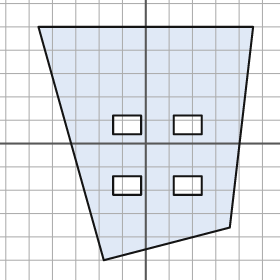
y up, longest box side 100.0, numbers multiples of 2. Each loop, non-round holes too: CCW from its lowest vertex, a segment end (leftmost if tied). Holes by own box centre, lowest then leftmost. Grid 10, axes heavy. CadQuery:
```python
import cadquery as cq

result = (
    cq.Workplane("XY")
    .moveTo(-18.0, -50.0)
    .lineTo(36.0, -36.0)
    .lineTo(46.0, 50.0)
    .lineTo(-46.0, 50.0)
    .close()
    .moveTo(-14.0, -22.0)
    .lineTo(-2.0, -22.0)
    .lineTo(-2.0, -14.0)
    .lineTo(-14.0, -14.0)
    .close()
    .moveTo(12.0, -22.0)
    .lineTo(24.0, -22.0)
    .lineTo(24.0, -14.0)
    .lineTo(12.0, -14.0)
    .close()
    .moveTo(-14.0, 4.0)
    .lineTo(-2.0, 4.0)
    .lineTo(-2.0, 12.0)
    .lineTo(-14.0, 12.0)
    .close()
    .moveTo(12.0, 4.0)
    .lineTo(24.0, 4.0)
    .lineTo(24.0, 12.0)
    .lineTo(12.0, 12.0)
    .close()
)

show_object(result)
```